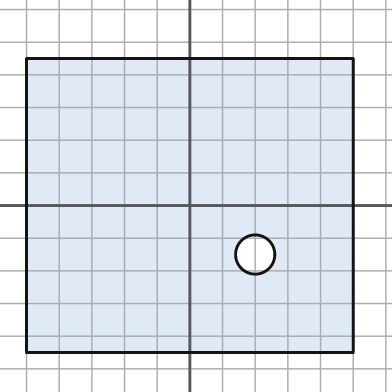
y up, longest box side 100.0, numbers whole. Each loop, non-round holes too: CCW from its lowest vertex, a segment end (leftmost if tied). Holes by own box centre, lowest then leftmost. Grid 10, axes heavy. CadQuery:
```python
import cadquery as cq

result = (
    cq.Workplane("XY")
    .moveTo(-50.0, -45.0)
    .lineTo(50.0, -45.0)
    .lineTo(50.0, 45.0)
    .lineTo(-50.0, 45.0)
    .close()
    .moveTo(20.0, -15.0)
    .circle(6.0)
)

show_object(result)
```